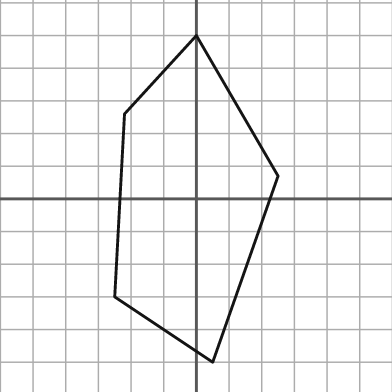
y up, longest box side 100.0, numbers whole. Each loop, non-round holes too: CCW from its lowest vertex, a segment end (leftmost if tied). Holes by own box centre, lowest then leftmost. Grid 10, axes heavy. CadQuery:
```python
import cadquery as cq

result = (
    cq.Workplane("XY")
    .moveTo(5.0, -50.0)
    .lineTo(25.0, 7.0)
    .lineTo(0.0, 50.0)
    .lineTo(-22.0, 26.0)
    .lineTo(-25.0, -30.0)
    .close()
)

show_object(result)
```